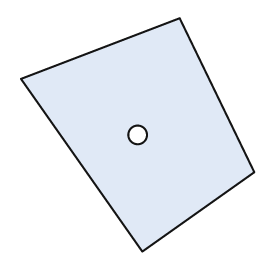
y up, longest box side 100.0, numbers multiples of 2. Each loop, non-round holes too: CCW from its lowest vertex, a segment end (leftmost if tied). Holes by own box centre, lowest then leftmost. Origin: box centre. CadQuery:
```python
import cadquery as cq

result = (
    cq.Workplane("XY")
    .moveTo(2.0, -50.0)
    .lineTo(50.0, -16.0)
    .lineTo(18.0, 50.0)
    .lineTo(-50.0, 24.0)
    .close()
    .moveTo(0.0, 0.0)
    .circle(4.0)
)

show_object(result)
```